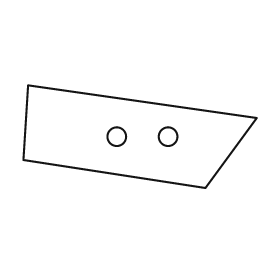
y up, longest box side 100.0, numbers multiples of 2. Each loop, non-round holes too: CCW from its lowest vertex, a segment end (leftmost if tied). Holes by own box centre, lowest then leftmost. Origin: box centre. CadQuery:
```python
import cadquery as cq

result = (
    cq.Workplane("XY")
    .moveTo(28.0, -22.0)
    .lineTo(50.0, 8.0)
    .lineTo(-48.0, 22.0)
    .lineTo(-50.0, -10.0)
    .close()
    .moveTo(-10.0, 0.0)
    .circle(4.0)
    .moveTo(12.0, 0.0)
    .circle(4.0)
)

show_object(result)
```